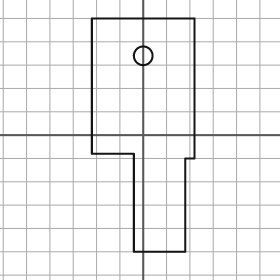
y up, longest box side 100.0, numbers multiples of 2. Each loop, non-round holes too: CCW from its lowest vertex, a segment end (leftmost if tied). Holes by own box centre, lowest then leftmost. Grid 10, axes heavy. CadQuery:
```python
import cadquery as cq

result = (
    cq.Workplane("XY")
    .moveTo(-4.0, -50.0)
    .lineTo(18.0, -50.0)
    .lineTo(18.0, -10.0)
    .lineTo(22.0, -10.0)
    .lineTo(22.0, 50.0)
    .lineTo(-22.0, 50.0)
    .lineTo(-22.0, -8.0)
    .lineTo(-4.0, -8.0)
    .close()
    .moveTo(0.0, 34.0)
    .circle(4.0)
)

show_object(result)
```